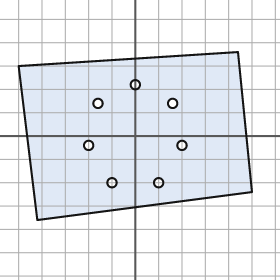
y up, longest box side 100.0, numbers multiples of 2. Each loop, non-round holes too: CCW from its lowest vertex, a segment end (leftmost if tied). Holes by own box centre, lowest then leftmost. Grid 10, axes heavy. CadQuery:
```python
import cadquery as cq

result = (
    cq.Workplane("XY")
    .moveTo(-42.0, -36.0)
    .lineTo(50.0, -24.0)
    .lineTo(44.0, 36.0)
    .lineTo(-50.0, 30.0)
    .close()
    .moveTo(-10.0, -20.0)
    .circle(2.0)
    .moveTo(10.0, -20.0)
    .circle(2.0)
    .moveTo(-20.0, -4.0)
    .circle(2.0)
    .moveTo(20.0, -4.0)
    .circle(2.0)
    .moveTo(-16.0, 14.0)
    .circle(2.0)
    .moveTo(16.0, 14.0)
    .circle(2.0)
    .moveTo(0.0, 22.0)
    .circle(2.0)
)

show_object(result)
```